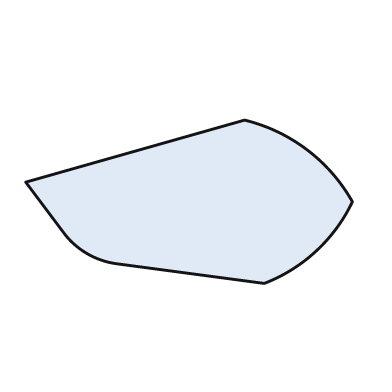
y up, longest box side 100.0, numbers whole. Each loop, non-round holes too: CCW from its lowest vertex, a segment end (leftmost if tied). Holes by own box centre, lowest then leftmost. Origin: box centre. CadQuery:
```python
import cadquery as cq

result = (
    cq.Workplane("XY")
    .moveTo(23.0, -25.0)
    .threePointArc((39.0, -15.0), (50.0, 0.0))
    .threePointArc((36.0, 16.0), (17.0, 25.0))
    .lineTo(-50.0, 6.0)
    .lineTo(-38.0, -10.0)
    .threePointArc((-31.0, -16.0), (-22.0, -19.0))
    .close()
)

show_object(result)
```